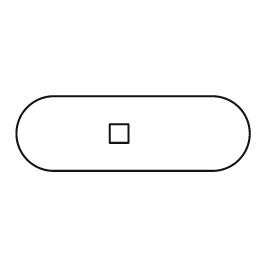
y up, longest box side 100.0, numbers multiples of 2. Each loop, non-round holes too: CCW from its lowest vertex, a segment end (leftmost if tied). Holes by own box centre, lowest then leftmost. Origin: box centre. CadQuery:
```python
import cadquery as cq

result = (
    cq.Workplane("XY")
    .moveTo(-34.0, -16.0)
    .lineTo(34.0, -16.0)
    .threePointArc((50.0, 0.0), (34.0, 16.0))
    .lineTo(-34.0, 16.0)
    .threePointArc((-50.0, 0.0), (-34.0, -16.0))
    .close()
    .moveTo(-10.0, -4.0)
    .lineTo(-2.0, -4.0)
    .lineTo(-2.0, 4.0)
    .lineTo(-10.0, 4.0)
    .close()
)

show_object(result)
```